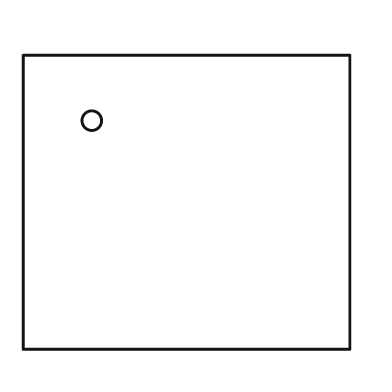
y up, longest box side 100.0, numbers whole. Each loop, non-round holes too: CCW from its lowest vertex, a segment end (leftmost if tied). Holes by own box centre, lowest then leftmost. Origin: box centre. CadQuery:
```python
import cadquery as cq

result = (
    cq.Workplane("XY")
    .moveTo(-50.0, -45.0)
    .lineTo(50.0, -45.0)
    .lineTo(50.0, 45.0)
    .lineTo(-50.0, 45.0)
    .close()
    .moveTo(-29.0, 25.0)
    .circle(3.0)
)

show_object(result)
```